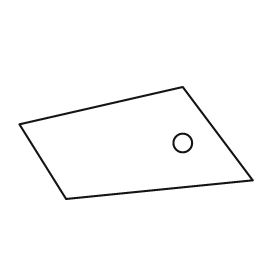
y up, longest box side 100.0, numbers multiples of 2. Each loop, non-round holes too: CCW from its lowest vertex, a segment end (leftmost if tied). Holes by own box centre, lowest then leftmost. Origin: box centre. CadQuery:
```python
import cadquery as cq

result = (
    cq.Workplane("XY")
    .moveTo(-30.0, -24.0)
    .lineTo(50.0, -16.0)
    .lineTo(20.0, 24.0)
    .lineTo(-50.0, 8.0)
    .close()
    .moveTo(20.0, 0.0)
    .circle(4.0)
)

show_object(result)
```